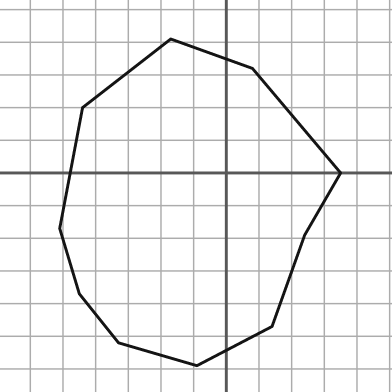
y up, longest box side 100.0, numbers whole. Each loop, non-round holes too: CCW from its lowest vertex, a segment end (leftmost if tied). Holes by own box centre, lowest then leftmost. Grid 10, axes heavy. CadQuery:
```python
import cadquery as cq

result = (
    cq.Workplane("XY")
    .moveTo(-9.0, -59.0)
    .lineTo(14.0, -47.0)
    .lineTo(24.0, -19.0)
    .lineTo(35.0, 0.0)
    .lineTo(8.0, 32.0)
    .lineTo(-17.0, 41.0)
    .lineTo(-44.0, 20.0)
    .lineTo(-51.0, -17.0)
    .lineTo(-45.0, -37.0)
    .lineTo(-33.0, -52.0)
    .close()
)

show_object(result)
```